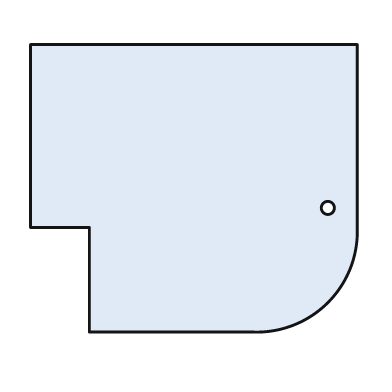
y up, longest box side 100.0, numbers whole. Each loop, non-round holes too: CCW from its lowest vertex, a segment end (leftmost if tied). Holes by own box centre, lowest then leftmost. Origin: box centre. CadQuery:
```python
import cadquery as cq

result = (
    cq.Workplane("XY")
    .moveTo(-32.0, -44.0)
    .lineTo(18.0, -44.0)
    .threePointArc((41.0, -35.0), (50.0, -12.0))
    .lineTo(50.0, 44.0)
    .lineTo(-50.0, 44.0)
    .lineTo(-50.0, -12.0)
    .lineTo(-32.0, -12.0)
    .close()
    .moveTo(41.0, -6.0)
    .circle(2.0)
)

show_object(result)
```